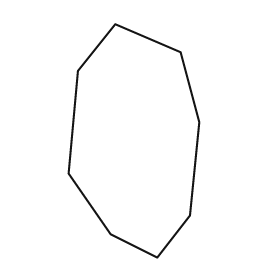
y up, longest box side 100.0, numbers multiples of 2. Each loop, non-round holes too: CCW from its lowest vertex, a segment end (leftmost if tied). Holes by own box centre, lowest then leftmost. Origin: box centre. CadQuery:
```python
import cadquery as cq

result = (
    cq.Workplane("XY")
    .moveTo(10.0, -50.0)
    .lineTo(24.0, -32.0)
    .lineTo(28.0, 8.0)
    .lineTo(20.0, 38.0)
    .lineTo(-8.0, 50.0)
    .lineTo(-24.0, 30.0)
    .lineTo(-28.0, -14.0)
    .lineTo(-10.0, -40.0)
    .close()
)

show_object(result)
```